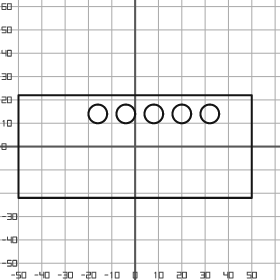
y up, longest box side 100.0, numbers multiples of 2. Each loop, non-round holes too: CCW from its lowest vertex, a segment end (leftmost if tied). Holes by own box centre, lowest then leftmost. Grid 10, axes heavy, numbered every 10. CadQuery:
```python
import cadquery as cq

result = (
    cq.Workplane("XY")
    .moveTo(-50.0, -22.0)
    .lineTo(50.0, -22.0)
    .lineTo(50.0, 22.0)
    .lineTo(-50.0, 22.0)
    .close()
    .moveTo(-16.0, 14.0)
    .circle(4.0)
    .moveTo(-4.0, 14.0)
    .circle(4.0)
    .moveTo(8.0, 14.0)
    .circle(4.0)
    .moveTo(20.0, 14.0)
    .circle(4.0)
    .moveTo(32.0, 14.0)
    .circle(4.0)
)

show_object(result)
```